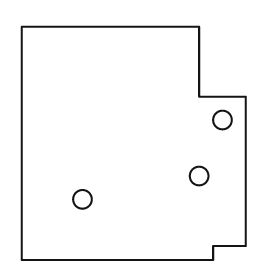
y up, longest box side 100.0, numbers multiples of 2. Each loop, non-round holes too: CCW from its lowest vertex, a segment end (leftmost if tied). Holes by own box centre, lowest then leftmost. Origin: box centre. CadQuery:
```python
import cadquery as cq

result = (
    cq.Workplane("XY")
    .moveTo(-48.0, -50.0)
    .lineTo(34.0, -50.0)
    .lineTo(34.0, -44.0)
    .lineTo(48.0, -44.0)
    .lineTo(48.0, 20.0)
    .lineTo(28.0, 20.0)
    .lineTo(28.0, 50.0)
    .lineTo(-48.0, 50.0)
    .close()
    .moveTo(-22.0, -24.0)
    .circle(4.0)
    .moveTo(28.0, -14.0)
    .circle(4.0)
    .moveTo(38.0, 10.0)
    .circle(4.0)
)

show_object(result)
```